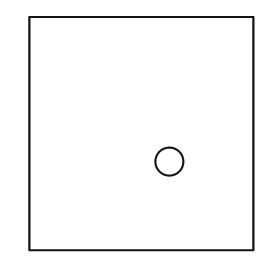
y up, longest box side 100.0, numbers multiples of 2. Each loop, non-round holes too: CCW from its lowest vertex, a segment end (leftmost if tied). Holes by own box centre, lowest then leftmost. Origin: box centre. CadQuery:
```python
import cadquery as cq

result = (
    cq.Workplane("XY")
    .moveTo(-48.0, -50.0)
    .lineTo(48.0, -50.0)
    .lineTo(48.0, 50.0)
    .lineTo(-48.0, 50.0)
    .close()
    .moveTo(12.0, -12.0)
    .circle(6.0)
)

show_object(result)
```